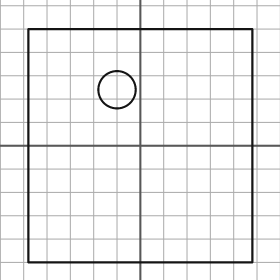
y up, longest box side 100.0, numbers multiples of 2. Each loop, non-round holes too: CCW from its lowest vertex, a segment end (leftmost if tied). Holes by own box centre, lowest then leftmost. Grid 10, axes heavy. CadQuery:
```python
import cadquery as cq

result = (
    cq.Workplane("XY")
    .moveTo(-48.0, -50.0)
    .lineTo(48.0, -50.0)
    .lineTo(48.0, 50.0)
    .lineTo(-48.0, 50.0)
    .close()
    .moveTo(-10.0, 24.0)
    .circle(8.0)
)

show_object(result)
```